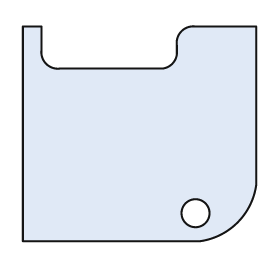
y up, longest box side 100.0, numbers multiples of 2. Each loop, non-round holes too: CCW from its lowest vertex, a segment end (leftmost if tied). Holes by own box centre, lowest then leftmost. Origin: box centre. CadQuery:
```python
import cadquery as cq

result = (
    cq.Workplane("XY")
    .moveTo(-50.0, -46.0)
    .lineTo(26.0, -46.0)
    .threePointArc((42.0, -38.0), (50.0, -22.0))
    .lineTo(50.0, 46.0)
    .lineTo(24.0, 46.0)
    .threePointArc((18.0, 44.0), (16.0, 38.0))
    .lineTo(16.0, 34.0)
    .threePointArc((14.0, 30.0), (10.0, 28.0))
    .lineTo(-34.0, 28.0)
    .threePointArc((-40.0, 30.0), (-42.0, 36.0))
    .lineTo(-42.0, 46.0)
    .lineTo(-50.0, 46.0)
    .close()
    .moveTo(24.0, -34.0)
    .circle(6.0)
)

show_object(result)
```